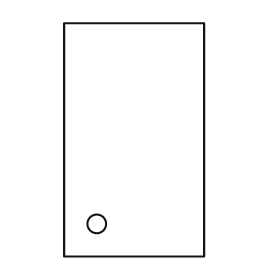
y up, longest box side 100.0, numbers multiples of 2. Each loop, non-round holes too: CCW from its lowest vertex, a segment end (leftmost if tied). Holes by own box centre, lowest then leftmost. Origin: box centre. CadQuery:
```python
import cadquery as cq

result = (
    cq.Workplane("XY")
    .moveTo(-30.0, -50.0)
    .lineTo(30.0, -50.0)
    .lineTo(30.0, 50.0)
    .lineTo(-30.0, 50.0)
    .close()
    .moveTo(-16.0, -36.0)
    .circle(4.0)
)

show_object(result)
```